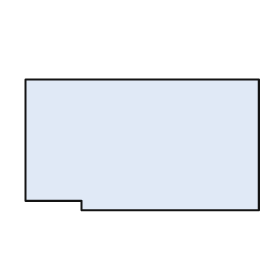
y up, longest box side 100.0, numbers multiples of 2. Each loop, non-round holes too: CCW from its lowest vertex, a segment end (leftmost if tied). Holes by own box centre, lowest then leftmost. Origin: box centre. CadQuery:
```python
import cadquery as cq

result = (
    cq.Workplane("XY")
    .moveTo(-26.0, -28.0)
    .lineTo(50.0, -28.0)
    .lineTo(50.0, 28.0)
    .lineTo(-50.0, 28.0)
    .lineTo(-50.0, -24.0)
    .lineTo(-26.0, -24.0)
    .close()
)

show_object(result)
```